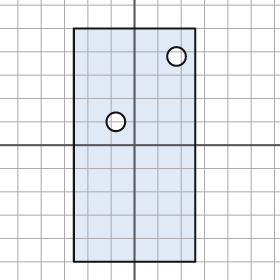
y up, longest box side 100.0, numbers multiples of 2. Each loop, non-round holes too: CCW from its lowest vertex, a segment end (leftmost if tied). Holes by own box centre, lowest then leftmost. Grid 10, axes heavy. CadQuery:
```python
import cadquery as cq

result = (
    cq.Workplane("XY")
    .moveTo(-26.0, -50.0)
    .lineTo(26.0, -50.0)
    .lineTo(26.0, 50.0)
    .lineTo(-26.0, 50.0)
    .close()
    .moveTo(-8.0, 10.0)
    .circle(4.0)
    .moveTo(18.0, 38.0)
    .circle(4.0)
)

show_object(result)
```